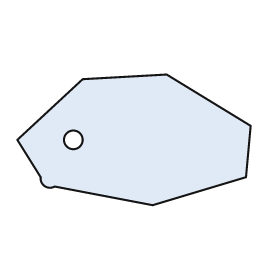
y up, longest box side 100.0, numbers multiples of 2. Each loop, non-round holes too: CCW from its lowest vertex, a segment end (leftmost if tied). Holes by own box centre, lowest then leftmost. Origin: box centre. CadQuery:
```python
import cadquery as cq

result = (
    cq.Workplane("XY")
    .moveTo(8.0, -28.0)
    .lineTo(48.0, -16.0)
    .lineTo(50.0, 6.0)
    .lineTo(14.0, 28.0)
    .lineTo(-22.0, 26.0)
    .lineTo(-50.0, 0.0)
    .lineTo(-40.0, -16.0)
    .threePointArc((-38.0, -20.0), (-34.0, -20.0))
    .close()
    .moveTo(-26.0, 0.0)
    .circle(4.0)
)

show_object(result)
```